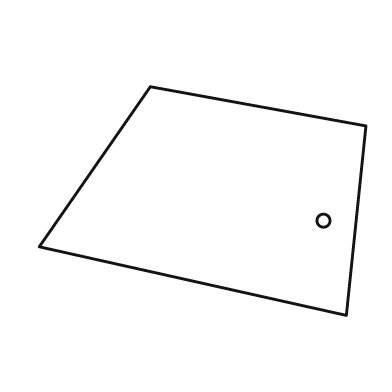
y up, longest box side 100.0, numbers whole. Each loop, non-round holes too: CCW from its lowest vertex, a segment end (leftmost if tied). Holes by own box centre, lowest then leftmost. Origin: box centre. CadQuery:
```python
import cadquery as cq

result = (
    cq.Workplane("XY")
    .moveTo(44.0, -35.0)
    .lineTo(50.0, 23.0)
    .lineTo(-16.0, 35.0)
    .lineTo(-50.0, -14.0)
    .close()
    .moveTo(37.0, -6.0)
    .circle(2.0)
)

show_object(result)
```